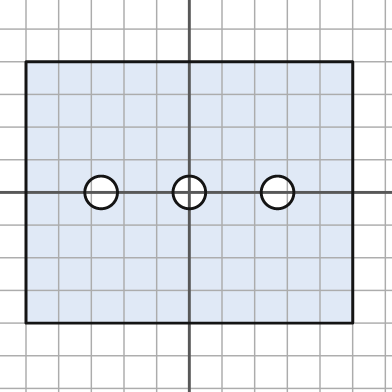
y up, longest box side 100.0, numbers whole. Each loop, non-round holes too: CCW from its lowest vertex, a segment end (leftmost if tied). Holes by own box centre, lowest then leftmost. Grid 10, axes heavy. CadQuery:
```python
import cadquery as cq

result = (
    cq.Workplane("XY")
    .moveTo(-50.0, -40.0)
    .lineTo(50.0, -40.0)
    .lineTo(50.0, 40.0)
    .lineTo(-50.0, 40.0)
    .close()
    .moveTo(-27.0, 0.0)
    .circle(5.0)
    .moveTo(0.0, 0.0)
    .circle(5.0)
    .moveTo(27.0, 0.0)
    .circle(5.0)
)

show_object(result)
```